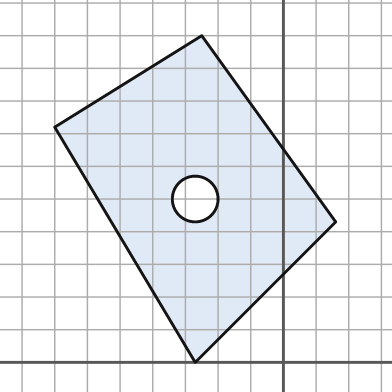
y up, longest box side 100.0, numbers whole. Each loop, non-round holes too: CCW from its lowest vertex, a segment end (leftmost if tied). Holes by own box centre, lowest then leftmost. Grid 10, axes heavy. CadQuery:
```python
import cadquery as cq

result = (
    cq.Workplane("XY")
    .moveTo(-27.0, 0.0)
    .lineTo(16.0, 43.0)
    .lineTo(-25.0, 100.0)
    .lineTo(-70.0, 72.0)
    .close()
    .moveTo(-27.0, 50.0)
    .circle(7.0)
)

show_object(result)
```